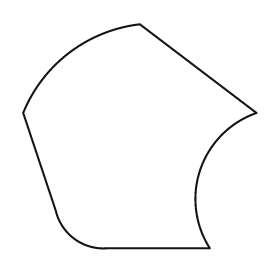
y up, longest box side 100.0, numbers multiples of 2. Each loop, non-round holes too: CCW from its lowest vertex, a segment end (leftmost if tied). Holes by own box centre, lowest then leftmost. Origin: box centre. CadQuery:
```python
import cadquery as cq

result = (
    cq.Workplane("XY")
    .moveTo(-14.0, -48.0)
    .lineTo(30.0, -48.0)
    .threePointArc((26.0, -14.0), (50.0, 10.0))
    .lineTo(0.0, 48.0)
    .threePointArc((-30.0, 36.0), (-50.0, 10.0))
    .lineTo(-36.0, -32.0)
    .threePointArc((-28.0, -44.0), (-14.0, -48.0))
    .close()
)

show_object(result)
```